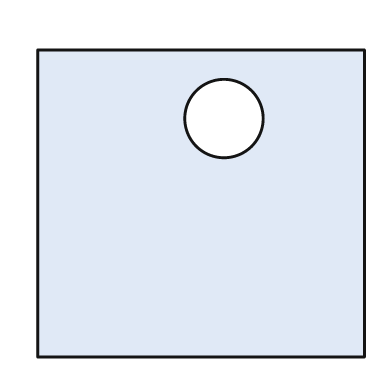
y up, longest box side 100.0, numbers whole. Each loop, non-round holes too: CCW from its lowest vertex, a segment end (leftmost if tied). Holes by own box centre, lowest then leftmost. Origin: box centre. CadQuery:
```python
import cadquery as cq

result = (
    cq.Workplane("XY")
    .moveTo(-50.0, -47.0)
    .lineTo(50.0, -47.0)
    .lineTo(50.0, 47.0)
    .lineTo(-50.0, 47.0)
    .close()
    .moveTo(7.0, 26.0)
    .circle(12.0)
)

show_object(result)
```